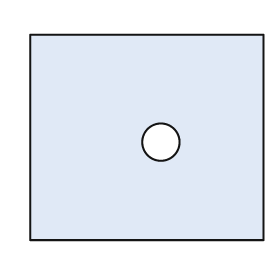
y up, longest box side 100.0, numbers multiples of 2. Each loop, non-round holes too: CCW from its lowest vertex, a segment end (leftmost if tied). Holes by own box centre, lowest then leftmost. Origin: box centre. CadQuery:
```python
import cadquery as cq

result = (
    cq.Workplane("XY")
    .moveTo(-50.0, -44.0)
    .lineTo(50.0, -44.0)
    .lineTo(50.0, 44.0)
    .lineTo(-50.0, 44.0)
    .close()
    .moveTo(6.0, -2.0)
    .circle(8.0)
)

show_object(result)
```